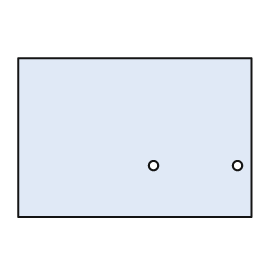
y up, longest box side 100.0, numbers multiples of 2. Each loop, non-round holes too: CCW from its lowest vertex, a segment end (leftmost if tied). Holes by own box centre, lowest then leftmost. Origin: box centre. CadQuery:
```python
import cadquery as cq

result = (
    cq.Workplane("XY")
    .moveTo(-50.0, -34.0)
    .lineTo(50.0, -34.0)
    .lineTo(50.0, 34.0)
    .lineTo(-50.0, 34.0)
    .close()
    .moveTo(8.0, -12.0)
    .circle(2.0)
    .moveTo(44.0, -12.0)
    .circle(2.0)
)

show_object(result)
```